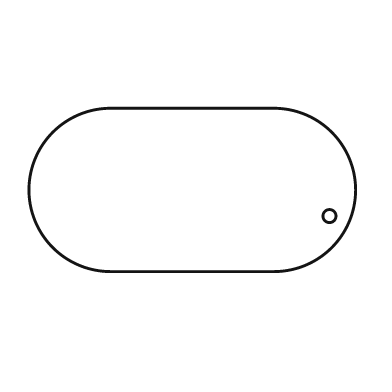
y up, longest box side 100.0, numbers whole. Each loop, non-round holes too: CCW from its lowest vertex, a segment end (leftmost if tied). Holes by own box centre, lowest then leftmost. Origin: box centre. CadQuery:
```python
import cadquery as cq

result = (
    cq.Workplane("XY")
    .moveTo(-25.0, -25.0)
    .lineTo(25.0, -25.0)
    .threePointArc((50.0, 0.0), (25.0, 25.0))
    .lineTo(-25.0, 25.0)
    .threePointArc((-50.0, 0.0), (-25.0, -25.0))
    .close()
    .moveTo(42.0, -8.0)
    .circle(2.0)
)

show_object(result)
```